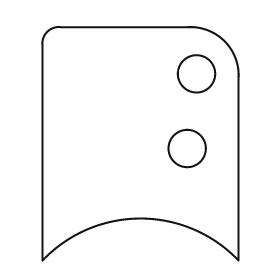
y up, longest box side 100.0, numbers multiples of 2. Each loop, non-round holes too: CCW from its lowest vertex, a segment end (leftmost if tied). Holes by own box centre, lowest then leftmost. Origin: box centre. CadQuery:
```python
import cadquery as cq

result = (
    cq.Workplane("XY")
    .moveTo(-42.0, -50.0)
    .threePointArc((0.0, -32.0), (42.0, -50.0))
    .lineTo(42.0, 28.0)
    .threePointArc((36.0, 44.0), (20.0, 50.0))
    .lineTo(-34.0, 50.0)
    .threePointArc((-40.0, 48.0), (-42.0, 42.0))
    .close()
    .moveTo(20.0, -2.0)
    .circle(8.0)
    .moveTo(24.0, 30.0)
    .circle(8.0)
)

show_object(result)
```